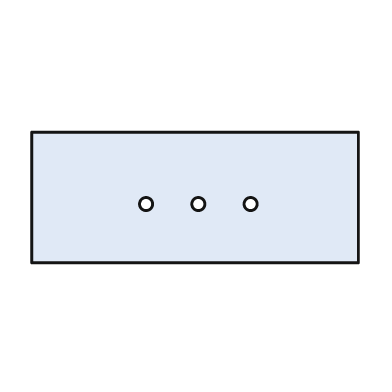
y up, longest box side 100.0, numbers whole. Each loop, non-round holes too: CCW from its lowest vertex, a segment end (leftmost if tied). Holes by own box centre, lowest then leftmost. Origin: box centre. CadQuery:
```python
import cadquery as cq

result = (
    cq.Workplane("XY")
    .moveTo(-50.0, -20.0)
    .lineTo(50.0, -20.0)
    .lineTo(50.0, 20.0)
    .lineTo(-50.0, 20.0)
    .close()
    .moveTo(-15.0, -2.0)
    .circle(2.0)
    .moveTo(1.0, -2.0)
    .circle(2.0)
    .moveTo(17.0, -2.0)
    .circle(2.0)
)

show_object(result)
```